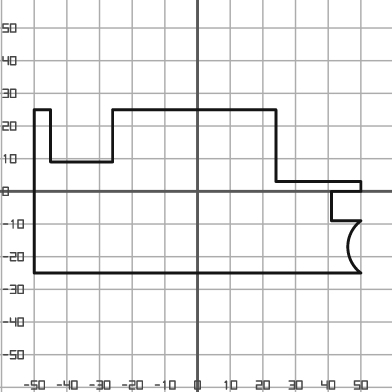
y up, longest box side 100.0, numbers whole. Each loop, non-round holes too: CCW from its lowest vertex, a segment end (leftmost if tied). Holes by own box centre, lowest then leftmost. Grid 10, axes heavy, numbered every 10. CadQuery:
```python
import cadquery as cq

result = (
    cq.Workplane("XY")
    .moveTo(-50.0, -25.0)
    .lineTo(50.0, -25.0)
    .threePointArc((46.0, -17.0), (50.0, -9.0))
    .lineTo(41.0, -9.0)
    .lineTo(41.0, 0.0)
    .lineTo(50.0, 0.0)
    .lineTo(50.0, 3.0)
    .lineTo(24.0, 3.0)
    .lineTo(24.0, 25.0)
    .lineTo(-26.0, 25.0)
    .lineTo(-26.0, 9.0)
    .lineTo(-45.0, 9.0)
    .lineTo(-45.0, 25.0)
    .lineTo(-50.0, 25.0)
    .close()
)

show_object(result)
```